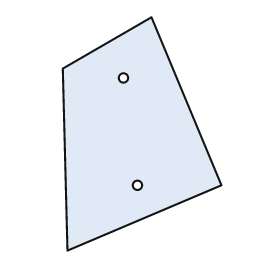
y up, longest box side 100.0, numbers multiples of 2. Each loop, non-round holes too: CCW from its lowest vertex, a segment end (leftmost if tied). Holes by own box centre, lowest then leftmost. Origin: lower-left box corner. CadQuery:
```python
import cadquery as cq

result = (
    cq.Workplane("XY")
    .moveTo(2.0, 0.0)
    .lineTo(68.0, 28.0)
    .lineTo(38.0, 100.0)
    .lineTo(0.0, 78.0)
    .close()
    .moveTo(32.0, 28.0)
    .circle(2.0)
    .moveTo(26.0, 74.0)
    .circle(2.0)
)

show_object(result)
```